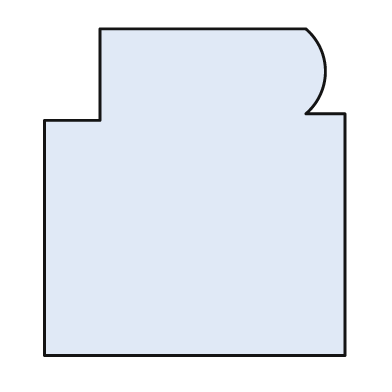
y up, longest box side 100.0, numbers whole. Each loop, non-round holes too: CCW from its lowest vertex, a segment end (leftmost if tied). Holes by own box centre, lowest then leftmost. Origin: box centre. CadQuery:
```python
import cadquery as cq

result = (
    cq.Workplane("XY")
    .moveTo(-46.0, -50.0)
    .lineTo(46.0, -50.0)
    .lineTo(46.0, 24.0)
    .lineTo(34.0, 24.0)
    .threePointArc((40.0, 37.0), (34.0, 50.0))
    .lineTo(-29.0, 50.0)
    .lineTo(-29.0, 22.0)
    .lineTo(-46.0, 22.0)
    .close()
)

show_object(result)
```